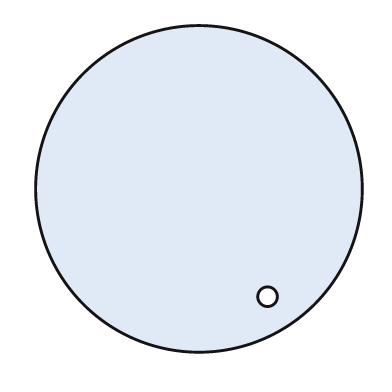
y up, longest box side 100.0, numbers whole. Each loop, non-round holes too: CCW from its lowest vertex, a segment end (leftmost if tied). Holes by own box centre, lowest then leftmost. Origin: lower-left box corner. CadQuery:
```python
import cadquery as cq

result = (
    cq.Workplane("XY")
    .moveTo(50.0, 50.0)
    .circle(50.0)
    .moveTo(71.0, 17.0)
    .circle(3.0)
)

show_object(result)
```